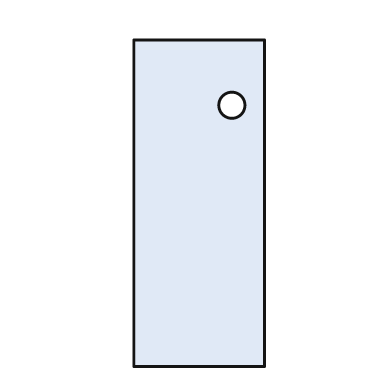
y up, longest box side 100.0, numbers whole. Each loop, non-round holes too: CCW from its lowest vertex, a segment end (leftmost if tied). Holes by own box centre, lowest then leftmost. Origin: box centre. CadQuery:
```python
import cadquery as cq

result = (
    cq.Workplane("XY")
    .moveTo(-20.0, -50.0)
    .lineTo(20.0, -50.0)
    .lineTo(20.0, 50.0)
    .lineTo(-20.0, 50.0)
    .close()
    .moveTo(10.0, 30.0)
    .circle(4.0)
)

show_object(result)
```